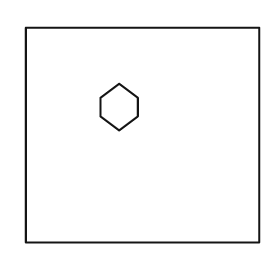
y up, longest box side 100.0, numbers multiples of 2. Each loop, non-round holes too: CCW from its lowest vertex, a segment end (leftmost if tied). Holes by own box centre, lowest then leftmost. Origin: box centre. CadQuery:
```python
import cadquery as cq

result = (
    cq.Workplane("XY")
    .moveTo(-50.0, -46.0)
    .lineTo(50.0, -46.0)
    .lineTo(50.0, 46.0)
    .lineTo(-50.0, 46.0)
    .close()
    .moveTo(-10.0, 2.0)
    .lineTo(-2.0, 8.0)
    .lineTo(-2.0, 16.0)
    .lineTo(-10.0, 22.0)
    .lineTo(-18.0, 16.0)
    .lineTo(-18.0, 8.0)
    .close()
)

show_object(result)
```